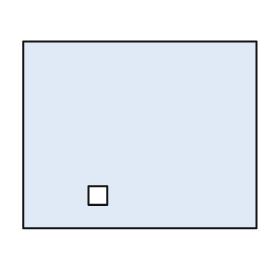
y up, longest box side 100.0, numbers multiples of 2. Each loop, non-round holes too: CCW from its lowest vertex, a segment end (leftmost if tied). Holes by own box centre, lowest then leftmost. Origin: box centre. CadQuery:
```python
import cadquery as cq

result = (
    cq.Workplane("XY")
    .moveTo(-50.0, -40.0)
    .lineTo(50.0, -40.0)
    .lineTo(50.0, 40.0)
    .lineTo(-50.0, 40.0)
    .close()
    .moveTo(-22.0, -30.0)
    .lineTo(-14.0, -30.0)
    .lineTo(-14.0, -22.0)
    .lineTo(-22.0, -22.0)
    .close()
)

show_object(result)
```